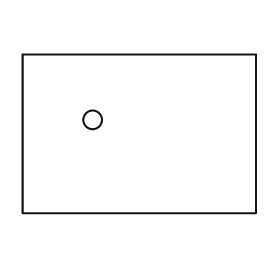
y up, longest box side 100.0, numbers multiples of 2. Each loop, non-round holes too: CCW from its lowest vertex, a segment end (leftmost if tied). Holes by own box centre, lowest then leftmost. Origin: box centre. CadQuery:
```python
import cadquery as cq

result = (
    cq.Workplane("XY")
    .moveTo(-50.0, -34.0)
    .lineTo(50.0, -34.0)
    .lineTo(50.0, 34.0)
    .lineTo(-50.0, 34.0)
    .close()
    .moveTo(-20.0, 6.0)
    .circle(4.0)
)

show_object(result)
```